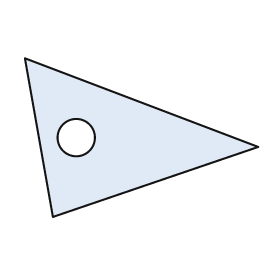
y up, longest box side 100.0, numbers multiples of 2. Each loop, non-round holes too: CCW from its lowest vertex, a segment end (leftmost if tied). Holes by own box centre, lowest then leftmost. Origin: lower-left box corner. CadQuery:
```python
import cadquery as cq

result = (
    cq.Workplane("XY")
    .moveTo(12.0, 0.0)
    .lineTo(100.0, 30.0)
    .lineTo(0.0, 68.0)
    .close()
    .moveTo(22.0, 34.0)
    .circle(8.0)
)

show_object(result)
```